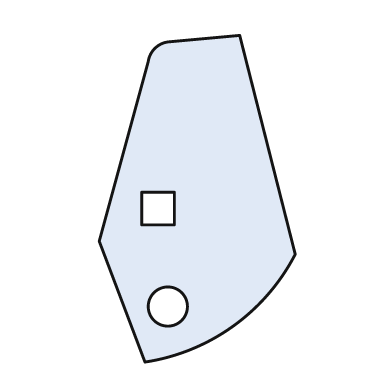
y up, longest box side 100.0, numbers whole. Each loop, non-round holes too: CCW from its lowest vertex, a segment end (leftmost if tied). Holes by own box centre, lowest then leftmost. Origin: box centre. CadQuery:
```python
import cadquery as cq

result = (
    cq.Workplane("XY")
    .moveTo(-16.0, -50.0)
    .threePointArc((11.0, -39.0), (30.0, -17.0))
    .lineTo(13.0, 50.0)
    .lineTo(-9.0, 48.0)
    .threePointArc((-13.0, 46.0), (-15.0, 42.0))
    .lineTo(-30.0, -13.0)
    .close()
    .moveTo(-9.0, -33.0)
    .circle(6.0)
    .moveTo(-17.0, -8.0)
    .lineTo(-7.0, -8.0)
    .lineTo(-7.0, 2.0)
    .lineTo(-17.0, 2.0)
    .close()
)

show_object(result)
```